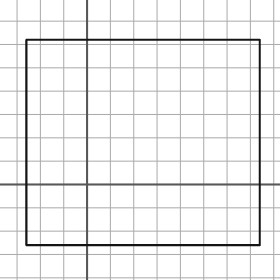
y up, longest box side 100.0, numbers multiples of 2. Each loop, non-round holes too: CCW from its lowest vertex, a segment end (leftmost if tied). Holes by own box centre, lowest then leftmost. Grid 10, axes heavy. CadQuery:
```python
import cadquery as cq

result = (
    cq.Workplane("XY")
    .moveTo(-26.0, -26.0)
    .lineTo(74.0, -26.0)
    .lineTo(74.0, 62.0)
    .lineTo(-26.0, 62.0)
    .close()
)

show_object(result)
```